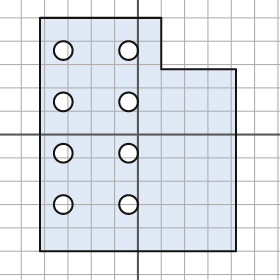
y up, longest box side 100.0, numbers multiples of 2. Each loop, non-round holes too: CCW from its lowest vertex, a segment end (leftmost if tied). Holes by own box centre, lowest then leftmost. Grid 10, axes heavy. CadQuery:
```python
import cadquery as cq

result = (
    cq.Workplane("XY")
    .moveTo(-42.0, -50.0)
    .lineTo(42.0, -50.0)
    .lineTo(42.0, 28.0)
    .lineTo(10.0, 28.0)
    .lineTo(10.0, 50.0)
    .lineTo(-42.0, 50.0)
    .close()
    .moveTo(-32.0, -30.0)
    .circle(4.0)
    .moveTo(-4.0, -30.0)
    .circle(4.0)
    .moveTo(-32.0, -8.0)
    .circle(4.0)
    .moveTo(-4.0, -8.0)
    .circle(4.0)
    .moveTo(-32.0, 14.0)
    .circle(4.0)
    .moveTo(-4.0, 14.0)
    .circle(4.0)
    .moveTo(-32.0, 36.0)
    .circle(4.0)
    .moveTo(-4.0, 36.0)
    .circle(4.0)
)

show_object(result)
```